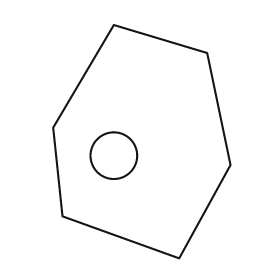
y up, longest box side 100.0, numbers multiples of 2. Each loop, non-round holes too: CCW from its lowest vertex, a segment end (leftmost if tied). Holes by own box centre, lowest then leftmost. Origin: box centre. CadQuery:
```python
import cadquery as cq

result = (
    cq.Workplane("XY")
    .moveTo(16.0, -50.0)
    .lineTo(38.0, -10.0)
    .lineTo(28.0, 38.0)
    .lineTo(-12.0, 50.0)
    .lineTo(-38.0, 6.0)
    .lineTo(-34.0, -32.0)
    .close()
    .moveTo(-12.0, -6.0)
    .circle(10.0)
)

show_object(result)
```